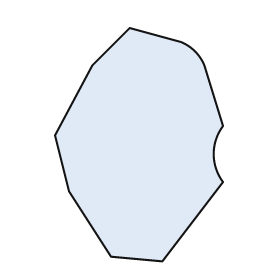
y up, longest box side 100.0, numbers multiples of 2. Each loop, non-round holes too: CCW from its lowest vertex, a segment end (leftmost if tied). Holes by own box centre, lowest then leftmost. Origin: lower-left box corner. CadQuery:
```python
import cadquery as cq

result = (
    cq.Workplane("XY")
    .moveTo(46.0, 0.0)
    .lineTo(72.0, 34.0)
    .threePointArc((68.0, 46.0), (72.0, 58.0))
    .lineTo(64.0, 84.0)
    .threePointArc((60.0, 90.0), (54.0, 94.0))
    .lineTo(32.0, 100.0)
    .lineTo(16.0, 84.0)
    .lineTo(0.0, 54.0)
    .lineTo(6.0, 30.0)
    .lineTo(24.0, 2.0)
    .close()
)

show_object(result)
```